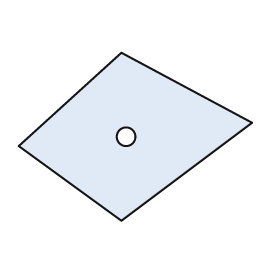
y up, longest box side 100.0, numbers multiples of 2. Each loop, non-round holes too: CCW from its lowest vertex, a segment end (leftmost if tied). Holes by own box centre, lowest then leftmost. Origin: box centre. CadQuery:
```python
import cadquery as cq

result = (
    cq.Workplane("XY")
    .moveTo(-6.0, -36.0)
    .lineTo(50.0, 6.0)
    .lineTo(-6.0, 36.0)
    .lineTo(-50.0, -4.0)
    .close()
    .moveTo(-4.0, 0.0)
    .circle(4.0)
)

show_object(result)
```